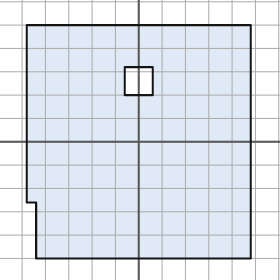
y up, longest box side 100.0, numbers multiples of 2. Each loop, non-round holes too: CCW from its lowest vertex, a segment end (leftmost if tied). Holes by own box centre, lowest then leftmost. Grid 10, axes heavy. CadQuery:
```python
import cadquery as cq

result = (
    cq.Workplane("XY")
    .moveTo(-44.0, -50.0)
    .lineTo(48.0, -50.0)
    .lineTo(48.0, 50.0)
    .lineTo(-48.0, 50.0)
    .lineTo(-48.0, -26.0)
    .lineTo(-44.0, -26.0)
    .close()
    .moveTo(-6.0, 20.0)
    .lineTo(6.0, 20.0)
    .lineTo(6.0, 32.0)
    .lineTo(-6.0, 32.0)
    .close()
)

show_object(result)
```